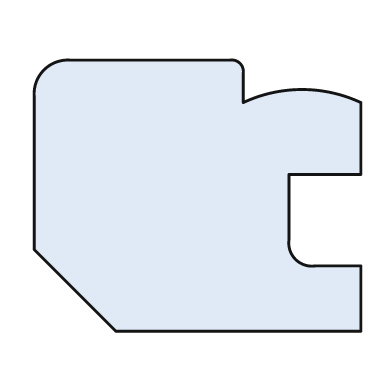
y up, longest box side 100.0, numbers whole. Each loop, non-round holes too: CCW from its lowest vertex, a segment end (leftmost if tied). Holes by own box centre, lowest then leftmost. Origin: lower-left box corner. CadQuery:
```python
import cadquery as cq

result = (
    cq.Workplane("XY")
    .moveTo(25.0, 0.0)
    .lineTo(100.0, 0.0)
    .lineTo(100.0, 20.0)
    .lineTo(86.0, 20.0)
    .threePointArc((80.0, 22.0), (78.0, 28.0))
    .lineTo(78.0, 48.0)
    .lineTo(100.0, 48.0)
    .lineTo(100.0, 70.0)
    .threePointArc((82.0, 74.0), (64.0, 70.0))
    .lineTo(64.0, 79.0)
    .threePointArc((63.0, 82.0), (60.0, 83.0))
    .lineTo(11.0, 83.0)
    .threePointArc((3.0, 80.0), (0.0, 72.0))
    .lineTo(0.0, 25.0)
    .close()
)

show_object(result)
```